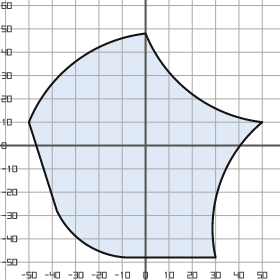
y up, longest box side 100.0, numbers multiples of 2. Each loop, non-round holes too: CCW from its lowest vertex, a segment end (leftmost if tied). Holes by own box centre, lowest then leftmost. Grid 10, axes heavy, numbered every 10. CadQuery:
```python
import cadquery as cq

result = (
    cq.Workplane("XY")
    .moveTo(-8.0, -48.0)
    .lineTo(30.0, -48.0)
    .threePointArc((32.0, -16.0), (50.0, 10.0))
    .threePointArc((20.0, 22.0), (0.0, 48.0))
    .threePointArc((-30.0, 36.0), (-50.0, 10.0))
    .lineTo(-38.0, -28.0)
    .threePointArc((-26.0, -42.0), (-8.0, -48.0))
    .close()
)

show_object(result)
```